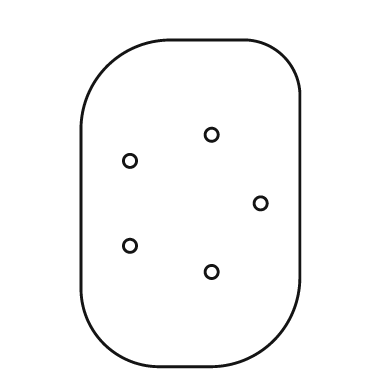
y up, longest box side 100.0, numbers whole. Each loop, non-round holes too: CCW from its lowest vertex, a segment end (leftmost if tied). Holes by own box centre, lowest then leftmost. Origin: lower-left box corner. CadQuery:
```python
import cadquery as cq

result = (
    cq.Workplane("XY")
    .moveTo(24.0, 0.0)
    .lineTo(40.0, 0.0)
    .threePointArc((59.0, 8.0), (67.0, 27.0))
    .lineTo(67.0, 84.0)
    .threePointArc((62.0, 95.0), (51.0, 100.0))
    .lineTo(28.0, 100.0)
    .threePointArc((8.0, 92.0), (0.0, 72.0))
    .lineTo(0.0, 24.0)
    .threePointArc((7.0, 7.0), (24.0, 0.0))
    .close()
    .moveTo(40.0, 29.0)
    .circle(2.0)
    .moveTo(15.0, 37.0)
    .circle(2.0)
    .moveTo(55.0, 50.0)
    .circle(2.0)
    .moveTo(15.0, 63.0)
    .circle(2.0)
    .moveTo(40.0, 71.0)
    .circle(2.0)
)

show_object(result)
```